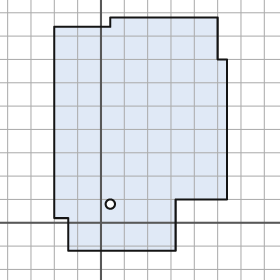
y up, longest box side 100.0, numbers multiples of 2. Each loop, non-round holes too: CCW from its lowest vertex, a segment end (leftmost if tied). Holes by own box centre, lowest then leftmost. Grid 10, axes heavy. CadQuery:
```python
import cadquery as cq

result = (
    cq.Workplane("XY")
    .moveTo(-14.0, -12.0)
    .lineTo(32.0, -12.0)
    .lineTo(32.0, 10.0)
    .lineTo(54.0, 10.0)
    .lineTo(54.0, 70.0)
    .lineTo(50.0, 70.0)
    .lineTo(50.0, 88.0)
    .lineTo(4.0, 88.0)
    .lineTo(4.0, 84.0)
    .lineTo(-20.0, 84.0)
    .lineTo(-20.0, 2.0)
    .lineTo(-14.0, 2.0)
    .close()
    .moveTo(4.0, 8.0)
    .circle(2.0)
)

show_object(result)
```